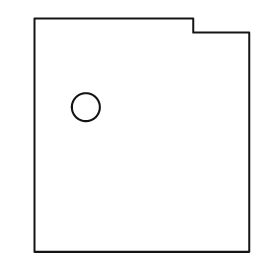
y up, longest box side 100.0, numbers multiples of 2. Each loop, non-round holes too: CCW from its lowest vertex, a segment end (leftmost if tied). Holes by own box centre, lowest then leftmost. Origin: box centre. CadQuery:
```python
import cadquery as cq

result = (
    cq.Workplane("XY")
    .moveTo(-46.0, -50.0)
    .lineTo(46.0, -50.0)
    .lineTo(46.0, 44.0)
    .lineTo(22.0, 44.0)
    .lineTo(22.0, 50.0)
    .lineTo(-46.0, 50.0)
    .close()
    .moveTo(-24.0, 12.0)
    .circle(6.0)
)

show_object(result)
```